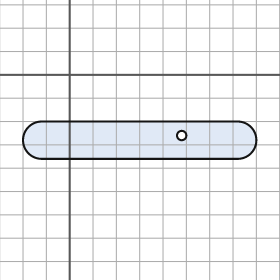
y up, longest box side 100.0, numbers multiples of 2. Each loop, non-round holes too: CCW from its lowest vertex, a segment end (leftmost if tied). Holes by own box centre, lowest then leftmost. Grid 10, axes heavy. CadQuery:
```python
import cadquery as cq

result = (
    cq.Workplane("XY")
    .moveTo(-12.0, -36.0)
    .lineTo(72.0, -36.0)
    .threePointArc((80.0, -28.0), (72.0, -20.0))
    .lineTo(-12.0, -20.0)
    .threePointArc((-20.0, -28.0), (-12.0, -36.0))
    .close()
    .moveTo(48.0, -26.0)
    .circle(2.0)
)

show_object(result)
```